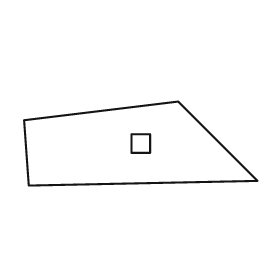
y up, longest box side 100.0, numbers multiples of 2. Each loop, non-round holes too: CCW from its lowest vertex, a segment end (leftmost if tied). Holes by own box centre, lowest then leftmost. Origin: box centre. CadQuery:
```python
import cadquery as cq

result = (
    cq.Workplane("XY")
    .moveTo(-48.0, -18.0)
    .lineTo(50.0, -16.0)
    .lineTo(16.0, 18.0)
    .lineTo(-50.0, 10.0)
    .close()
    .moveTo(-4.0, -4.0)
    .lineTo(4.0, -4.0)
    .lineTo(4.0, 4.0)
    .lineTo(-4.0, 4.0)
    .close()
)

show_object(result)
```